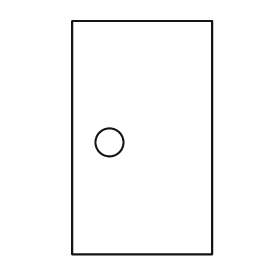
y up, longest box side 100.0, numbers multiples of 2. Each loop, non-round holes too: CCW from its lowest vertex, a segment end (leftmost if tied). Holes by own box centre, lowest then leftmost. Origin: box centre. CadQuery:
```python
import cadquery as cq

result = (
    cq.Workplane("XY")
    .moveTo(-30.0, -50.0)
    .lineTo(30.0, -50.0)
    .lineTo(30.0, 50.0)
    .lineTo(-30.0, 50.0)
    .close()
    .moveTo(-14.0, -2.0)
    .circle(6.0)
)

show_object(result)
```